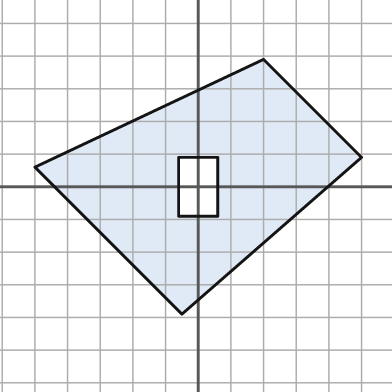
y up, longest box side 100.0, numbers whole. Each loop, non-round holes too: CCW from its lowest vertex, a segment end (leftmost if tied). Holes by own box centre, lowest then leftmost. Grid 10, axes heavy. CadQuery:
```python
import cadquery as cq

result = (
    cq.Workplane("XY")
    .moveTo(-5.0, -39.0)
    .lineTo(50.0, 9.0)
    .lineTo(20.0, 39.0)
    .lineTo(-50.0, 6.0)
    .close()
    .moveTo(-6.0, -9.0)
    .lineTo(6.0, -9.0)
    .lineTo(6.0, 9.0)
    .lineTo(-6.0, 9.0)
    .close()
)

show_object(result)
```